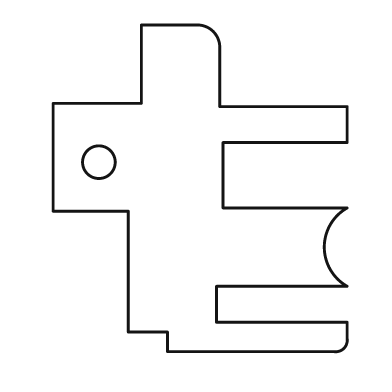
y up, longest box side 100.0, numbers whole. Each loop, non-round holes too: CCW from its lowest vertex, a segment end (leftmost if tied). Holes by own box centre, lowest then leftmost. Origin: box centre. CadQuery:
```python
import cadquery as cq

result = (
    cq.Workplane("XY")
    .moveTo(-10.0, -50.0)
    .lineTo(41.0, -50.0)
    .threePointArc((44.0, -49.0), (45.0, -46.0))
    .lineTo(45.0, -41.0)
    .lineTo(5.0, -41.0)
    .lineTo(5.0, -30.0)
    .lineTo(45.0, -30.0)
    .threePointArc((38.0, -18.0), (45.0, -6.0))
    .lineTo(7.0, -6.0)
    .lineTo(7.0, 14.0)
    .lineTo(45.0, 14.0)
    .lineTo(45.0, 25.0)
    .lineTo(6.0, 25.0)
    .lineTo(6.0, 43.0)
    .threePointArc((4.0, 48.0), (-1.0, 50.0))
    .lineTo(-18.0, 50.0)
    .lineTo(-18.0, 26.0)
    .lineTo(-45.0, 26.0)
    .lineTo(-45.0, -7.0)
    .lineTo(-22.0, -7.0)
    .lineTo(-22.0, -44.0)
    .lineTo(-10.0, -44.0)
    .close()
    .moveTo(-31.0, 8.0)
    .circle(5.0)
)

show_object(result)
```